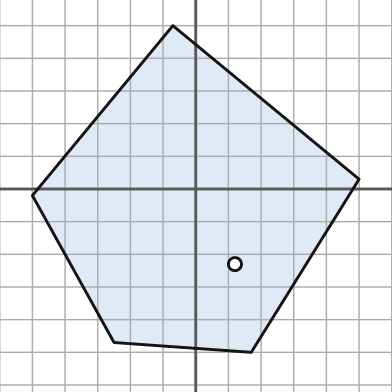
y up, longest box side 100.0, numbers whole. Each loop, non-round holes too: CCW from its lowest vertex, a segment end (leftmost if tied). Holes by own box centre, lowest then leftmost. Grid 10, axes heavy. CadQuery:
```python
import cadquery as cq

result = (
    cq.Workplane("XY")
    .moveTo(17.0, -50.0)
    .lineTo(50.0, 3.0)
    .lineTo(-7.0, 50.0)
    .lineTo(-50.0, -2.0)
    .lineTo(-25.0, -47.0)
    .close()
    .moveTo(12.0, -23.0)
    .circle(2.0)
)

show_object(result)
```